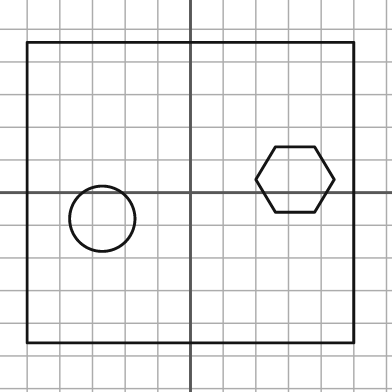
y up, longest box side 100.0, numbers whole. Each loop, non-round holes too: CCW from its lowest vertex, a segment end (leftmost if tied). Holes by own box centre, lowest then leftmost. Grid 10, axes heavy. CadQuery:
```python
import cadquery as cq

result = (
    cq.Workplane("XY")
    .moveTo(-50.0, -46.0)
    .lineTo(50.0, -46.0)
    .lineTo(50.0, 46.0)
    .lineTo(-50.0, 46.0)
    .close()
    .moveTo(-27.0, -8.0)
    .circle(10.0)
    .moveTo(26.0, -6.0)
    .lineTo(38.0, -6.0)
    .lineTo(44.0, 4.0)
    .lineTo(38.0, 14.0)
    .lineTo(26.0, 14.0)
    .lineTo(20.0, 4.0)
    .close()
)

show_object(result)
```